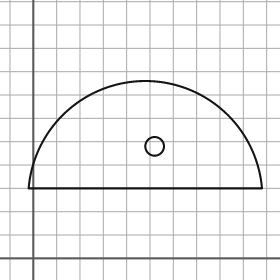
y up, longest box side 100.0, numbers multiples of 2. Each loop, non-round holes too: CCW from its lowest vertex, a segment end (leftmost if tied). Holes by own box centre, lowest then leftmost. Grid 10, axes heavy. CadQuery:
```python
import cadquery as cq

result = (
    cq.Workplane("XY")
    .moveTo(-2.0, 30.0)
    .lineTo(98.0, 30.0)
    .threePointArc((48.0, 76.0), (-2.0, 30.0))
    .close()
    .moveTo(52.0, 48.0)
    .circle(4.0)
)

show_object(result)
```